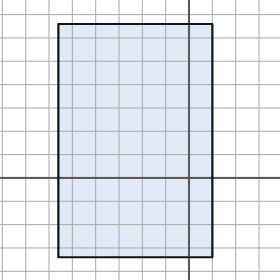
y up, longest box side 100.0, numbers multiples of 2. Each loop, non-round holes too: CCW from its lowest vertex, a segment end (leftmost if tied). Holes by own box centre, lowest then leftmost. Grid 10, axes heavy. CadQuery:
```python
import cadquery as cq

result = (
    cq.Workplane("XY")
    .moveTo(-56.0, -34.0)
    .lineTo(10.0, -34.0)
    .lineTo(10.0, 66.0)
    .lineTo(-56.0, 66.0)
    .close()
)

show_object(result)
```